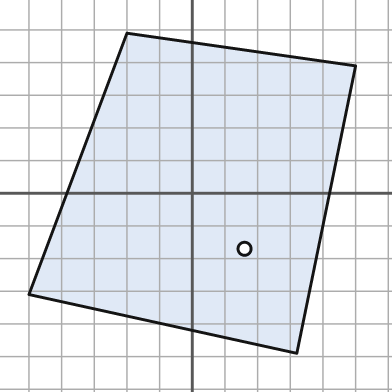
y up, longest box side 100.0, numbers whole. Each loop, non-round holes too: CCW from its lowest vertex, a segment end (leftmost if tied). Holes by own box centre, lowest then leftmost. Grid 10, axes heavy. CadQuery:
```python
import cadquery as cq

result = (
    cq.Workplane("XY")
    .moveTo(32.0, -49.0)
    .lineTo(50.0, 39.0)
    .lineTo(-20.0, 49.0)
    .lineTo(-50.0, -31.0)
    .close()
    .moveTo(16.0, -17.0)
    .circle(2.0)
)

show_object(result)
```